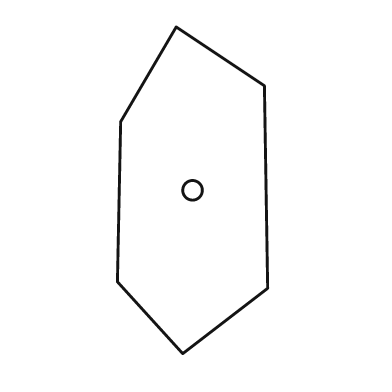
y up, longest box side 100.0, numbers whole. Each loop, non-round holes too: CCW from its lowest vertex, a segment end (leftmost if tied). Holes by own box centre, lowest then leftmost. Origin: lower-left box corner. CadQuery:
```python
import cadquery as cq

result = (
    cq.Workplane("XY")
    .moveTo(20.0, 0.0)
    .lineTo(46.0, 20.0)
    .lineTo(45.0, 82.0)
    .lineTo(18.0, 100.0)
    .lineTo(1.0, 71.0)
    .lineTo(0.0, 22.0)
    .close()
    .moveTo(23.0, 50.0)
    .circle(3.0)
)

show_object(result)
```